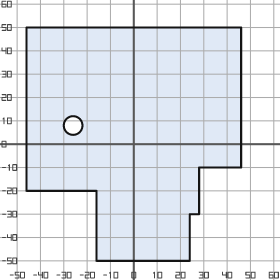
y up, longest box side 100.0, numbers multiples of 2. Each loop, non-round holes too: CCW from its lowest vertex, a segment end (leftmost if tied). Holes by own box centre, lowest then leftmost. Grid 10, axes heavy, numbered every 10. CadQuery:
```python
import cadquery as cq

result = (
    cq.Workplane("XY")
    .moveTo(-16.0, -50.0)
    .lineTo(24.0, -50.0)
    .lineTo(24.0, -30.0)
    .lineTo(28.0, -30.0)
    .lineTo(28.0, -10.0)
    .lineTo(46.0, -10.0)
    .lineTo(46.0, 50.0)
    .lineTo(-46.0, 50.0)
    .lineTo(-46.0, -20.0)
    .lineTo(-16.0, -20.0)
    .close()
    .moveTo(-26.0, 8.0)
    .circle(4.0)
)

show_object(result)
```